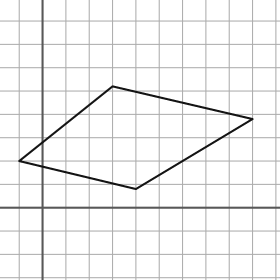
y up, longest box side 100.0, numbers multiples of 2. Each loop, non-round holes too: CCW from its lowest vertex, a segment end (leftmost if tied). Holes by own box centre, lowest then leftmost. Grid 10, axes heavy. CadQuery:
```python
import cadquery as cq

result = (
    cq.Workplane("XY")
    .moveTo(40.0, 8.0)
    .lineTo(90.0, 38.0)
    .lineTo(30.0, 52.0)
    .lineTo(-10.0, 20.0)
    .close()
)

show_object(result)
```